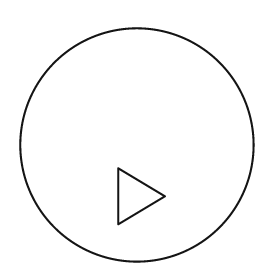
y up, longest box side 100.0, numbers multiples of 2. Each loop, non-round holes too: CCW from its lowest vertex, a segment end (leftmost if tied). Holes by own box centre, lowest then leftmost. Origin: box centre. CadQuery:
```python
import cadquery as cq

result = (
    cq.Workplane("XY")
    .moveTo(0.0, 0.0)
    .circle(50.0)
    .moveTo(-8.0, -34.0)
    .lineTo(12.0, -22.0)
    .lineTo(-8.0, -10.0)
    .close()
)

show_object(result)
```